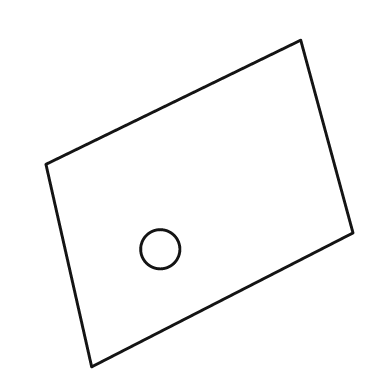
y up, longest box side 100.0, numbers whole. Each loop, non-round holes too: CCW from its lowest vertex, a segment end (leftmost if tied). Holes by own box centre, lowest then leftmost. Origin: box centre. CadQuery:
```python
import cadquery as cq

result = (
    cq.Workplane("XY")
    .moveTo(-33.0, -50.0)
    .lineTo(47.0, -9.0)
    .lineTo(31.0, 50.0)
    .lineTo(-47.0, 12.0)
    .close()
    .moveTo(-12.0, -14.0)
    .circle(6.0)
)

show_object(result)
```